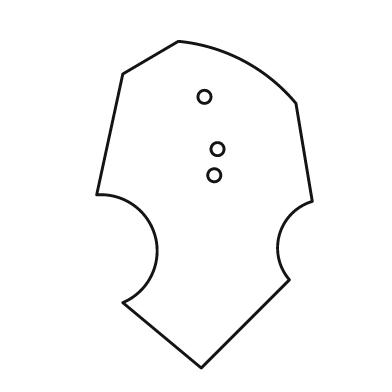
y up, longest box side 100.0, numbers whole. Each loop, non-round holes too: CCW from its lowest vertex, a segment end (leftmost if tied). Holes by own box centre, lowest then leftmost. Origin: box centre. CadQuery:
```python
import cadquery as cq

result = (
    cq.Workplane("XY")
    .moveTo(-1.0, -50.0)
    .lineTo(26.0, -23.0)
    .threePointArc((23.0, -9.0), (33.0, 1.0))
    .lineTo(28.0, 31.0)
    .threePointArc((12.0, 44.0), (-8.0, 50.0))
    .lineTo(-25.0, 40.0)
    .lineTo(-33.0, 3.0)
    .threePointArc((-15.0, -10.0), (-25.0, -30.0))
    .close()
    .moveTo(3.0, 9.0)
    .circle(2.0)
    .moveTo(4.0, 17.0)
    .circle(2.0)
    .moveTo(0.0, 33.0)
    .circle(2.0)
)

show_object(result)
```